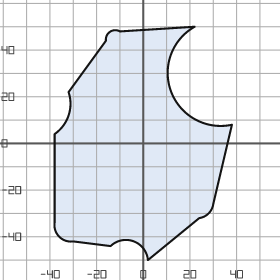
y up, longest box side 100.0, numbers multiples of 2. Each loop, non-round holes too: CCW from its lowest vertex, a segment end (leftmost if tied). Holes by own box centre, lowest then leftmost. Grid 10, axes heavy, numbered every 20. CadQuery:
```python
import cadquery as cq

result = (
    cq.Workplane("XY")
    .moveTo(2.0, -50.0)
    .lineTo(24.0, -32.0)
    .threePointArc((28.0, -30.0), (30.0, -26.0))
    .lineTo(38.0, 8.0)
    .threePointArc((12.0, 22.0), (22.0, 50.0))
    .lineTo(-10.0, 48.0)
    .threePointArc((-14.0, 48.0), (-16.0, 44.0))
    .lineTo(-32.0, 22.0)
    .threePointArc((-32.0, 12.0), (-38.0, 4.0))
    .lineTo(-38.0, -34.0)
    .threePointArc((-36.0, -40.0), (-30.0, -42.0))
    .lineTo(-14.0, -44.0)
    .threePointArc((-4.0, -42.0), (2.0, -50.0))
    .close()
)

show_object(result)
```